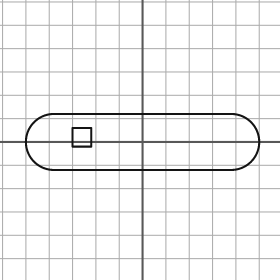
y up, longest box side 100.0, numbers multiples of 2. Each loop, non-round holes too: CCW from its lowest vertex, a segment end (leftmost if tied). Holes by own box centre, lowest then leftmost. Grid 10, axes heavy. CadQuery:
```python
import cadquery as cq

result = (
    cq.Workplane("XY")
    .moveTo(-38.0, -12.0)
    .lineTo(38.0, -12.0)
    .threePointArc((50.0, 0.0), (38.0, 12.0))
    .lineTo(-38.0, 12.0)
    .threePointArc((-50.0, 0.0), (-38.0, -12.0))
    .close()
    .moveTo(-30.0, -2.0)
    .lineTo(-22.0, -2.0)
    .lineTo(-22.0, 6.0)
    .lineTo(-30.0, 6.0)
    .close()
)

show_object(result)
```